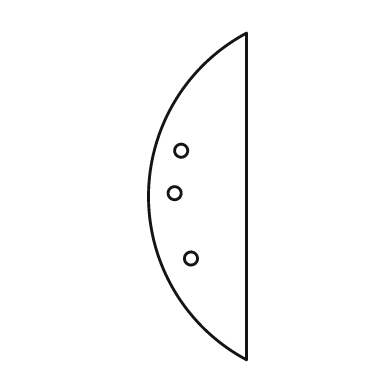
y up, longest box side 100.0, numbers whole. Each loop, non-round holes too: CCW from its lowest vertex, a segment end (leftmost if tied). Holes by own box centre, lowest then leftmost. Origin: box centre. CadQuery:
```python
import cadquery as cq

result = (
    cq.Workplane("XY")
    .moveTo(15.0, -50.0)
    .lineTo(15.0, 50.0)
    .threePointArc((-15.0, 0.0), (15.0, -50.0))
    .close()
    .moveTo(-2.0, -19.0)
    .circle(2.0)
    .moveTo(-7.0, 1.0)
    .circle(2.0)
    .moveTo(-5.0, 14.0)
    .circle(2.0)
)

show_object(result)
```